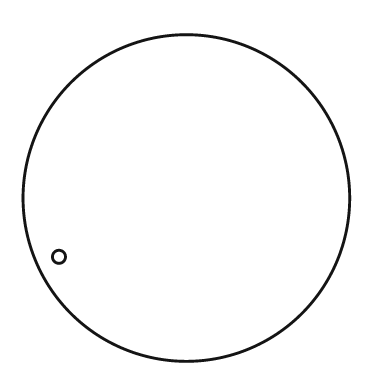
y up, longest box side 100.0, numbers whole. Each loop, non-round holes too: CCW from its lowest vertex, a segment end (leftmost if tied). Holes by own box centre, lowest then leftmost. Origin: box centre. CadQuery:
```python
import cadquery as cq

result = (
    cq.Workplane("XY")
    .moveTo(0.0, 0.0)
    .circle(50.0)
    .moveTo(-39.0, -18.0)
    .circle(2.0)
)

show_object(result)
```